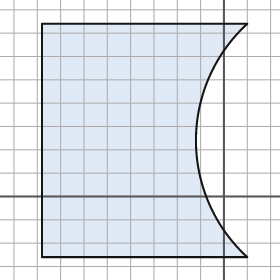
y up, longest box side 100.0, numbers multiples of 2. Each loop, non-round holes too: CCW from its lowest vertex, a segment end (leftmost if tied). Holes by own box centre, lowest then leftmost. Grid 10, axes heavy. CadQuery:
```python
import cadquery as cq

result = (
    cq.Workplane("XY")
    .moveTo(-78.0, -26.0)
    .lineTo(10.0, -26.0)
    .threePointArc((-12.0, 24.0), (10.0, 74.0))
    .lineTo(-78.0, 74.0)
    .close()
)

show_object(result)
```